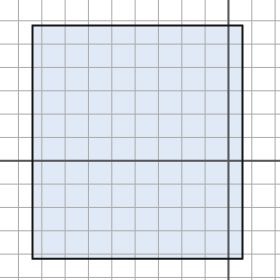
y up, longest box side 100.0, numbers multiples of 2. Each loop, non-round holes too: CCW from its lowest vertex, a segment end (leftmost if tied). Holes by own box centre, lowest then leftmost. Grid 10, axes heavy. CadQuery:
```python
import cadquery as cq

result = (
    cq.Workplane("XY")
    .moveTo(-84.0, -42.0)
    .lineTo(6.0, -42.0)
    .lineTo(6.0, 58.0)
    .lineTo(-84.0, 58.0)
    .close()
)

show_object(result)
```